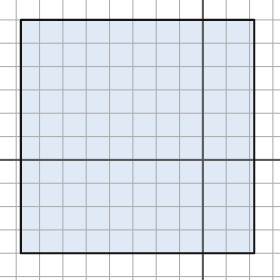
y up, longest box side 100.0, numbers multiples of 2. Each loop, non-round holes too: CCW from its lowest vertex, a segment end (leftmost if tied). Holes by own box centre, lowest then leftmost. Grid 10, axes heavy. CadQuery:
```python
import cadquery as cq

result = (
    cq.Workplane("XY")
    .moveTo(-78.0, -40.0)
    .lineTo(22.0, -40.0)
    .lineTo(22.0, 60.0)
    .lineTo(-78.0, 60.0)
    .close()
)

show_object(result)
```